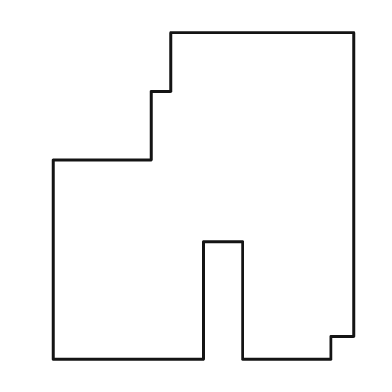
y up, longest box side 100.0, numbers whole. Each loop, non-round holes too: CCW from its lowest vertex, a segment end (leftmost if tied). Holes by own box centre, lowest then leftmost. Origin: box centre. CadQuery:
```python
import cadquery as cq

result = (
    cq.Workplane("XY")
    .moveTo(-46.0, -50.0)
    .lineTo(0.0, -50.0)
    .lineTo(0.0, -14.0)
    .lineTo(12.0, -14.0)
    .lineTo(12.0, -50.0)
    .lineTo(39.0, -50.0)
    .lineTo(39.0, -43.0)
    .lineTo(46.0, -43.0)
    .lineTo(46.0, 50.0)
    .lineTo(-10.0, 50.0)
    .lineTo(-10.0, 32.0)
    .lineTo(-16.0, 32.0)
    .lineTo(-16.0, 11.0)
    .lineTo(-46.0, 11.0)
    .close()
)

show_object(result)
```